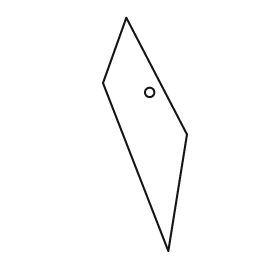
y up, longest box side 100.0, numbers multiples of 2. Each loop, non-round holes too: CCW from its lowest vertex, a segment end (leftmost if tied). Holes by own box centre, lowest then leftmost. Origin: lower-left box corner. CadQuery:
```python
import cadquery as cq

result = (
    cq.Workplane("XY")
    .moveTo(28.0, 0.0)
    .lineTo(36.0, 50.0)
    .lineTo(10.0, 100.0)
    .lineTo(0.0, 72.0)
    .close()
    .moveTo(20.0, 68.0)
    .circle(2.0)
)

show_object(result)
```